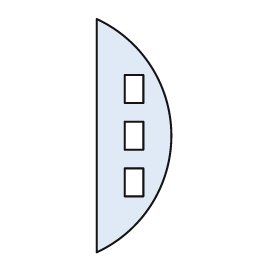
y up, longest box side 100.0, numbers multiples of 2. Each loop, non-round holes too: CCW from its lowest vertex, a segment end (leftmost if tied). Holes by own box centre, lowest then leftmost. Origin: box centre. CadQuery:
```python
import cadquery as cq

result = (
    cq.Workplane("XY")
    .moveTo(-16.0, -50.0)
    .threePointArc((16.0, 0.0), (-16.0, 50.0))
    .close()
    .moveTo(-4.0, -26.0)
    .lineTo(4.0, -26.0)
    .lineTo(4.0, -14.0)
    .lineTo(-4.0, -14.0)
    .close()
    .moveTo(-4.0, -6.0)
    .lineTo(4.0, -6.0)
    .lineTo(4.0, 6.0)
    .lineTo(-4.0, 6.0)
    .close()
    .moveTo(-4.0, 14.0)
    .lineTo(4.0, 14.0)
    .lineTo(4.0, 26.0)
    .lineTo(-4.0, 26.0)
    .close()
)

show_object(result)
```